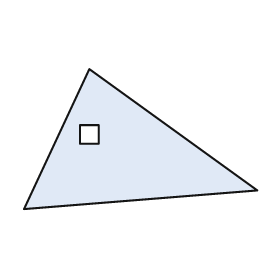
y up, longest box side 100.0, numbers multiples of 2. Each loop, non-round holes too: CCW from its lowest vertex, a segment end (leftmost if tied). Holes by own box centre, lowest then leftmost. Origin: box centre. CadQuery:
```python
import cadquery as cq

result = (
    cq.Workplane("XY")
    .moveTo(-50.0, -30.0)
    .lineTo(50.0, -22.0)
    .lineTo(-22.0, 30.0)
    .close()
    .moveTo(-26.0, -2.0)
    .lineTo(-18.0, -2.0)
    .lineTo(-18.0, 6.0)
    .lineTo(-26.0, 6.0)
    .close()
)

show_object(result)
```